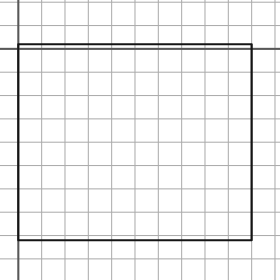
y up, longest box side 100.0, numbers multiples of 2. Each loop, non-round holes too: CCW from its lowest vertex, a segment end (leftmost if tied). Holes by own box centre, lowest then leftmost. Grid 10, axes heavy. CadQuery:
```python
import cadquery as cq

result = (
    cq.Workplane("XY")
    .moveTo(0.0, -82.0)
    .lineTo(100.0, -82.0)
    .lineTo(100.0, 2.0)
    .lineTo(0.0, 2.0)
    .close()
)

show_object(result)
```